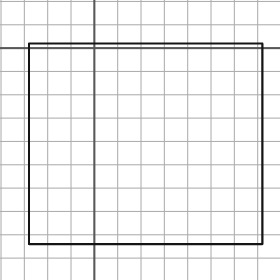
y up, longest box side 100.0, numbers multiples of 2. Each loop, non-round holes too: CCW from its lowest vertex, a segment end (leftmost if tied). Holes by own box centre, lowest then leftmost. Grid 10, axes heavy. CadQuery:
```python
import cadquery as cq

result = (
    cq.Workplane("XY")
    .moveTo(-28.0, -84.0)
    .lineTo(72.0, -84.0)
    .lineTo(72.0, 2.0)
    .lineTo(-28.0, 2.0)
    .close()
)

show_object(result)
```